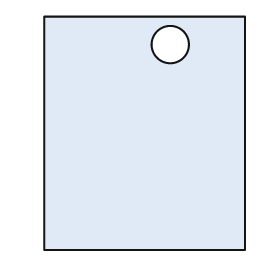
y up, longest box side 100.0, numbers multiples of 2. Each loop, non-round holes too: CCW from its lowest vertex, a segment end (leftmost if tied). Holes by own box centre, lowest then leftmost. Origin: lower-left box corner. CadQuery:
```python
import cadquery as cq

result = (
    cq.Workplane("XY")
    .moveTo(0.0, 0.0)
    .lineTo(86.0, 0.0)
    .lineTo(86.0, 100.0)
    .lineTo(0.0, 100.0)
    .close()
    .moveTo(54.0, 88.0)
    .circle(8.0)
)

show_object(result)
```